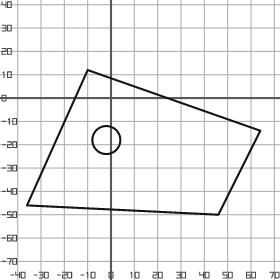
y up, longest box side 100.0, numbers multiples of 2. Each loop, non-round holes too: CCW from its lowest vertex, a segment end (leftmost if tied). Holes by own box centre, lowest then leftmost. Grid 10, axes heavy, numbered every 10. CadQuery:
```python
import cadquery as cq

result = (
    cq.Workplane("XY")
    .moveTo(46.0, -50.0)
    .lineTo(64.0, -14.0)
    .lineTo(-10.0, 12.0)
    .lineTo(-36.0, -46.0)
    .close()
    .moveTo(-2.0, -18.0)
    .circle(6.0)
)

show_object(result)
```